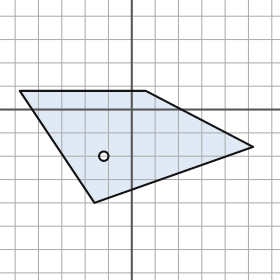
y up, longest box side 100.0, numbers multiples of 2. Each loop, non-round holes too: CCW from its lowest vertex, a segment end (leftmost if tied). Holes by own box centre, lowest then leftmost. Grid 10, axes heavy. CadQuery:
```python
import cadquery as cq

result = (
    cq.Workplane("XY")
    .moveTo(-16.0, -40.0)
    .lineTo(52.0, -16.0)
    .lineTo(6.0, 8.0)
    .lineTo(-48.0, 8.0)
    .close()
    .moveTo(-12.0, -20.0)
    .circle(2.0)
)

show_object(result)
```